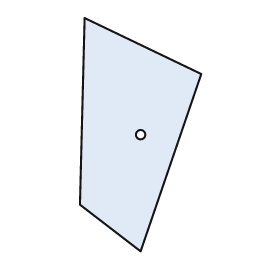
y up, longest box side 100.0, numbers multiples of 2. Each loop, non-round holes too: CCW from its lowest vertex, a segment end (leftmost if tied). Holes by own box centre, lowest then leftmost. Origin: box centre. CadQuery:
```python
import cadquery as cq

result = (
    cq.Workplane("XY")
    .moveTo(0.0, -50.0)
    .lineTo(26.0, 26.0)
    .lineTo(-24.0, 50.0)
    .lineTo(-26.0, -30.0)
    .close()
    .moveTo(0.0, 0.0)
    .circle(2.0)
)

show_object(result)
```